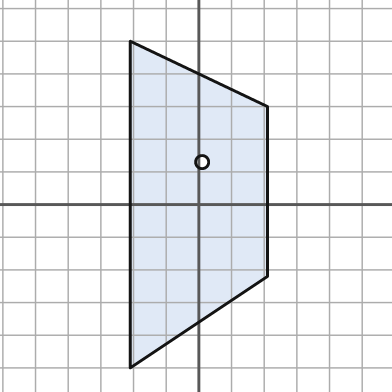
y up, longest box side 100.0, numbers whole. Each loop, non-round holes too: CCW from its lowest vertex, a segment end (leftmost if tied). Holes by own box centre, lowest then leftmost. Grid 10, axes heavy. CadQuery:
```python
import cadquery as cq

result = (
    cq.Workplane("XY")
    .moveTo(-21.0, -50.0)
    .lineTo(21.0, -22.0)
    .lineTo(21.0, 30.0)
    .lineTo(-21.0, 50.0)
    .close()
    .moveTo(1.0, 13.0)
    .circle(2.0)
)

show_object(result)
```